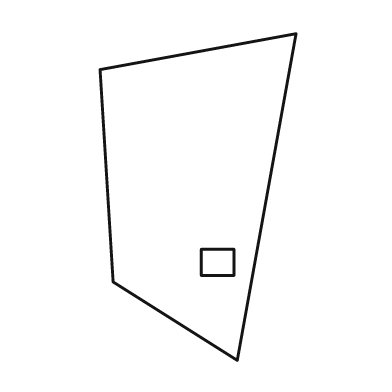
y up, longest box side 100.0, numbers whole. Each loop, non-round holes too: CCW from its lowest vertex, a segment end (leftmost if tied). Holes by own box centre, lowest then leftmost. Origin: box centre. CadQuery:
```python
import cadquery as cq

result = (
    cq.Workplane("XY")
    .moveTo(12.0, -50.0)
    .lineTo(30.0, 50.0)
    .lineTo(-30.0, 39.0)
    .lineTo(-26.0, -26.0)
    .close()
    .moveTo(1.0, -24.0)
    .lineTo(11.0, -24.0)
    .lineTo(11.0, -16.0)
    .lineTo(1.0, -16.0)
    .close()
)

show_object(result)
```